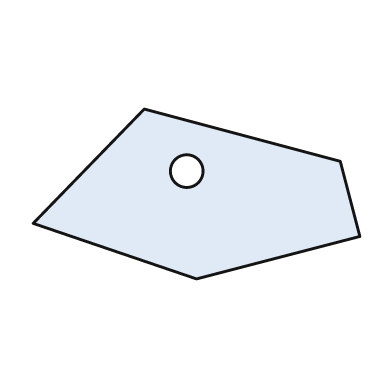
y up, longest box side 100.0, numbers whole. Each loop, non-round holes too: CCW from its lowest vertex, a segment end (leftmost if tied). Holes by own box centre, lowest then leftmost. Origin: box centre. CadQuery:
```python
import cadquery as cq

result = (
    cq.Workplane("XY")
    .moveTo(0.0, -26.0)
    .lineTo(50.0, -13.0)
    .lineTo(44.0, 10.0)
    .lineTo(-16.0, 26.0)
    .lineTo(-50.0, -9.0)
    .close()
    .moveTo(-3.0, 7.0)
    .circle(5.0)
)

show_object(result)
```